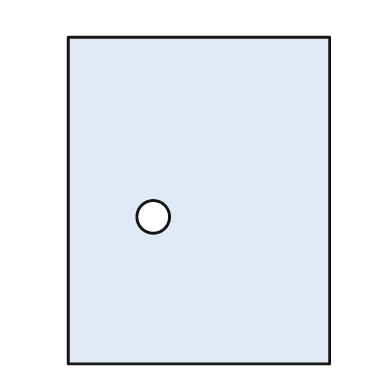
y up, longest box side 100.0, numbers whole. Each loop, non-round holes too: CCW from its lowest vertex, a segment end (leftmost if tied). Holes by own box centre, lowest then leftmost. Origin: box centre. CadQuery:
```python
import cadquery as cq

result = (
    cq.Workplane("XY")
    .moveTo(-40.0, -50.0)
    .lineTo(40.0, -50.0)
    .lineTo(40.0, 50.0)
    .lineTo(-40.0, 50.0)
    .close()
    .moveTo(-14.0, -5.0)
    .circle(5.0)
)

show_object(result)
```